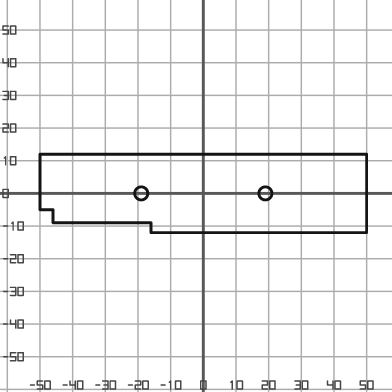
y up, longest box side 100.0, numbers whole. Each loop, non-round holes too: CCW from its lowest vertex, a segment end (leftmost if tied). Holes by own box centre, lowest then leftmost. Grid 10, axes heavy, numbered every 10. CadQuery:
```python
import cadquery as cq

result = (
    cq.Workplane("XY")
    .moveTo(-16.0, -12.0)
    .lineTo(50.0, -12.0)
    .lineTo(50.0, 12.0)
    .lineTo(-50.0, 12.0)
    .lineTo(-50.0, -5.0)
    .lineTo(-46.0, -5.0)
    .lineTo(-46.0, -9.0)
    .lineTo(-16.0, -9.0)
    .close()
    .moveTo(-19.0, 0.0)
    .circle(2.0)
    .moveTo(19.0, 0.0)
    .circle(2.0)
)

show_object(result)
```